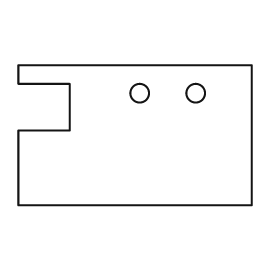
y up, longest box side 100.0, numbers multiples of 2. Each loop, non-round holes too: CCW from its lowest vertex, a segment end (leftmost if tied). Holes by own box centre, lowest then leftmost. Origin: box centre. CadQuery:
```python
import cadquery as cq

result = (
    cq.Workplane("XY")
    .moveTo(-50.0, -30.0)
    .lineTo(50.0, -30.0)
    .lineTo(50.0, 30.0)
    .lineTo(-50.0, 30.0)
    .lineTo(-50.0, 22.0)
    .lineTo(-28.0, 22.0)
    .lineTo(-28.0, 2.0)
    .lineTo(-50.0, 2.0)
    .close()
    .moveTo(2.0, 18.0)
    .circle(4.0)
    .moveTo(26.0, 18.0)
    .circle(4.0)
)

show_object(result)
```